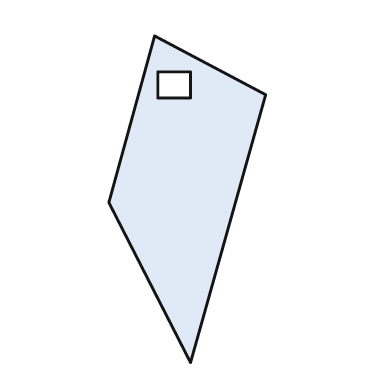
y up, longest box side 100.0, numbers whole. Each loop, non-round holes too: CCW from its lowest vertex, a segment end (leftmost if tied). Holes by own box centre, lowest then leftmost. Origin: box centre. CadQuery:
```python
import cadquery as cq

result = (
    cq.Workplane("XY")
    .moveTo(1.0, -50.0)
    .lineTo(24.0, 32.0)
    .lineTo(-10.0, 50.0)
    .lineTo(-24.0, -1.0)
    .close()
    .moveTo(-9.0, 31.0)
    .lineTo(1.0, 31.0)
    .lineTo(1.0, 39.0)
    .lineTo(-9.0, 39.0)
    .close()
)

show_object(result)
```